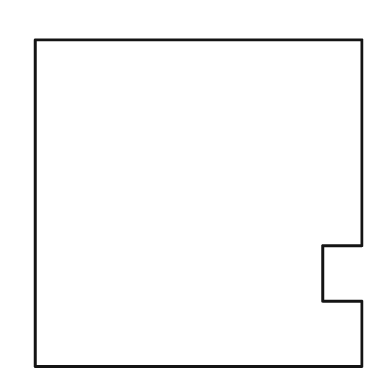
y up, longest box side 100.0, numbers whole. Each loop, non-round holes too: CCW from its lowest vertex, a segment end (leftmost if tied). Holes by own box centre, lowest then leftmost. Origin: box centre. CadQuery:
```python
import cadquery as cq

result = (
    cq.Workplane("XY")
    .moveTo(-50.0, -50.0)
    .lineTo(50.0, -50.0)
    .lineTo(50.0, -30.0)
    .lineTo(38.0, -30.0)
    .lineTo(38.0, -13.0)
    .lineTo(50.0, -13.0)
    .lineTo(50.0, 50.0)
    .lineTo(-50.0, 50.0)
    .close()
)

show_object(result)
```